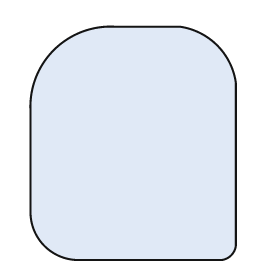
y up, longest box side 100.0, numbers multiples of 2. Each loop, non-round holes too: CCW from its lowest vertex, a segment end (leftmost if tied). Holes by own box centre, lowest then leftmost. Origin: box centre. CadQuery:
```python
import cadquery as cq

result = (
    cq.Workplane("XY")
    .moveTo(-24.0, -50.0)
    .lineTo(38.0, -50.0)
    .threePointArc((42.0, -48.0), (44.0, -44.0))
    .lineTo(44.0, 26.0)
    .threePointArc((36.0, 42.0), (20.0, 50.0))
    .lineTo(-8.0, 50.0)
    .threePointArc((-34.0, 40.0), (-44.0, 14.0))
    .lineTo(-44.0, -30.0)
    .threePointArc((-38.0, -44.0), (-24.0, -50.0))
    .close()
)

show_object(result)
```